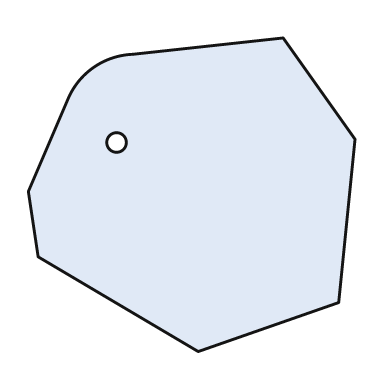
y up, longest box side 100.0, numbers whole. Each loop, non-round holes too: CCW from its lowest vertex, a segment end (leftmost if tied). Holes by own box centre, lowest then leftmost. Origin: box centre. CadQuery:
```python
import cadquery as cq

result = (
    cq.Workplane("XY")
    .moveTo(2.0, -48.0)
    .lineTo(45.0, -33.0)
    .lineTo(50.0, 17.0)
    .lineTo(28.0, 48.0)
    .lineTo(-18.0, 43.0)
    .threePointArc((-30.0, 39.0), (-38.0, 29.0))
    .lineTo(-50.0, 1.0)
    .lineTo(-47.0, -19.0)
    .close()
    .moveTo(-23.0, 16.0)
    .circle(3.0)
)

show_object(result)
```